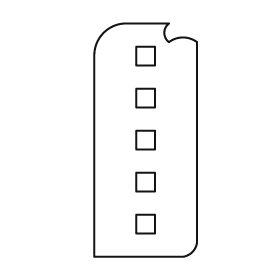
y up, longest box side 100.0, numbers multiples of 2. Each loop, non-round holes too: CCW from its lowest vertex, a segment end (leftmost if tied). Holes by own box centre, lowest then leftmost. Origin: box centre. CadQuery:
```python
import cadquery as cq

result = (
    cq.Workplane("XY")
    .moveTo(-22.0, -50.0)
    .lineTo(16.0, -50.0)
    .threePointArc((20.0, -48.0), (22.0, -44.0))
    .lineTo(22.0, 42.0)
    .threePointArc((16.0, 44.0), (10.0, 42.0))
    .threePointArc((8.0, 46.0), (10.0, 50.0))
    .lineTo(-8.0, 50.0)
    .threePointArc((-18.0, 46.0), (-22.0, 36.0))
    .close()
    .moveTo(-4.0, -40.0)
    .lineTo(4.0, -40.0)
    .lineTo(4.0, -32.0)
    .lineTo(-4.0, -32.0)
    .close()
    .moveTo(-4.0, -22.0)
    .lineTo(4.0, -22.0)
    .lineTo(4.0, -14.0)
    .lineTo(-4.0, -14.0)
    .close()
    .moveTo(-4.0, -4.0)
    .lineTo(4.0, -4.0)
    .lineTo(4.0, 4.0)
    .lineTo(-4.0, 4.0)
    .close()
    .moveTo(-4.0, 14.0)
    .lineTo(4.0, 14.0)
    .lineTo(4.0, 22.0)
    .lineTo(-4.0, 22.0)
    .close()
    .moveTo(-4.0, 32.0)
    .lineTo(4.0, 32.0)
    .lineTo(4.0, 40.0)
    .lineTo(-4.0, 40.0)
    .close()
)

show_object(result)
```